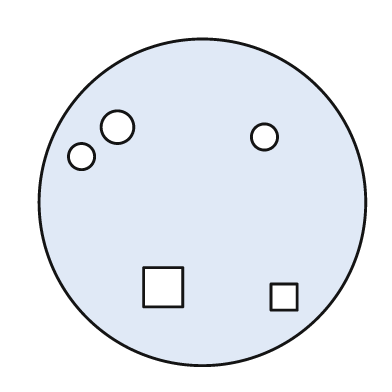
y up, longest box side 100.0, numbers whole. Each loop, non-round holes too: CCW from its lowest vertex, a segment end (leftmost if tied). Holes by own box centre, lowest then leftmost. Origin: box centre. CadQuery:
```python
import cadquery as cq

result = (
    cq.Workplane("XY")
    .moveTo(0.0, 0.0)
    .circle(50.0)
    .moveTo(21.0, -33.0)
    .lineTo(29.0, -33.0)
    .lineTo(29.0, -25.0)
    .lineTo(21.0, -25.0)
    .close()
    .moveTo(-18.0, -32.0)
    .lineTo(-6.0, -32.0)
    .lineTo(-6.0, -20.0)
    .lineTo(-18.0, -20.0)
    .close()
    .moveTo(-37.0, 14.0)
    .circle(4.0)
    .moveTo(19.0, 20.0)
    .circle(4.0)
    .moveTo(-26.0, 23.0)
    .circle(5.0)
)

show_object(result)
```